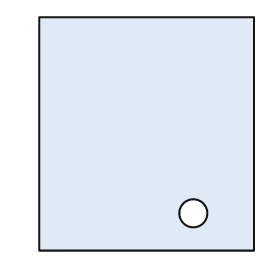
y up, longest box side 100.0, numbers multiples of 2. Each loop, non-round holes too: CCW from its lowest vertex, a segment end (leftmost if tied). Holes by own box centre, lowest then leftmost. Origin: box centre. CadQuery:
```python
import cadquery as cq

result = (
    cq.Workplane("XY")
    .moveTo(-46.0, -50.0)
    .lineTo(46.0, -50.0)
    .lineTo(46.0, 50.0)
    .lineTo(-46.0, 50.0)
    .close()
    .moveTo(20.0, -34.0)
    .circle(6.0)
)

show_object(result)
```